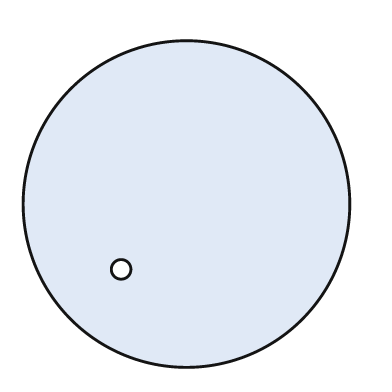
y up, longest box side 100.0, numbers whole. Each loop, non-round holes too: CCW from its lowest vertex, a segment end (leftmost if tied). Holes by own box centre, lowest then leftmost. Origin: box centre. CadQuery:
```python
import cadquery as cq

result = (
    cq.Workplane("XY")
    .moveTo(0.0, 0.0)
    .circle(50.0)
    .moveTo(-20.0, -20.0)
    .circle(3.0)
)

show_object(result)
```